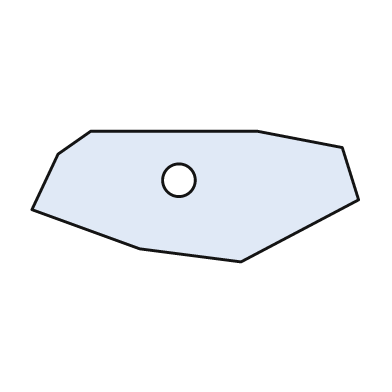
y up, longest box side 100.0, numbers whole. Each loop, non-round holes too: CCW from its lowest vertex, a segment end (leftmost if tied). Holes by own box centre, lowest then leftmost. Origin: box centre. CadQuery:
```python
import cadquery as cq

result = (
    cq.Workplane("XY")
    .moveTo(14.0, -20.0)
    .lineTo(50.0, -1.0)
    .lineTo(45.0, 15.0)
    .lineTo(19.0, 20.0)
    .lineTo(-32.0, 20.0)
    .lineTo(-42.0, 13.0)
    .lineTo(-50.0, -4.0)
    .lineTo(-17.0, -16.0)
    .close()
    .moveTo(-5.0, 5.0)
    .circle(5.0)
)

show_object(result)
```